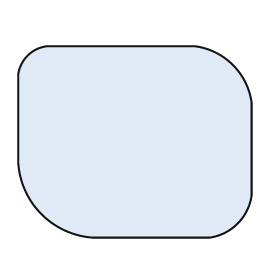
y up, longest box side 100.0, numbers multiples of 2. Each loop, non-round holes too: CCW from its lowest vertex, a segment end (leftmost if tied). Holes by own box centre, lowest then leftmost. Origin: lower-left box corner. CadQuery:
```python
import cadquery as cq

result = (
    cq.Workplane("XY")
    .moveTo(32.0, 0.0)
    .lineTo(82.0, 0.0)
    .threePointArc((94.0, 6.0), (100.0, 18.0))
    .lineTo(100.0, 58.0)
    .threePointArc((92.0, 74.0), (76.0, 82.0))
    .lineTo(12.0, 82.0)
    .threePointArc((4.0, 78.0), (0.0, 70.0))
    .lineTo(0.0, 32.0)
    .threePointArc((10.0, 10.0), (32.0, 0.0))
    .close()
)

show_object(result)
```